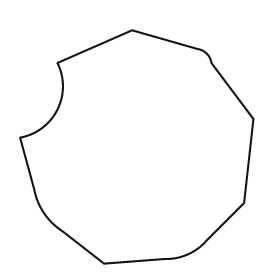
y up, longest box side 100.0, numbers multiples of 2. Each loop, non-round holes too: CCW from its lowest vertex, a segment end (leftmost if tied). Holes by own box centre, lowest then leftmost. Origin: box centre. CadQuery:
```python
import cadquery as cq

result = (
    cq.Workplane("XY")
    .moveTo(-14.0, -50.0)
    .lineTo(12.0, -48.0)
    .threePointArc((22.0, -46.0), (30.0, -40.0))
    .lineTo(46.0, -24.0)
    .lineTo(50.0, 12.0)
    .lineTo(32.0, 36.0)
    .threePointArc((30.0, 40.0), (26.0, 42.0))
    .lineTo(-2.0, 50.0)
    .lineTo(-34.0, 36.0)
    .threePointArc((-34.0, 16.0), (-50.0, 4.0))
    .lineTo(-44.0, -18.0)
    .threePointArc((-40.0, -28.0), (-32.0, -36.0))
    .close()
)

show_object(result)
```